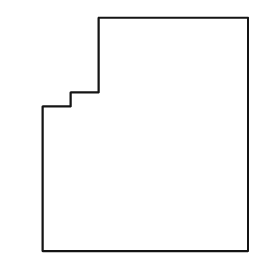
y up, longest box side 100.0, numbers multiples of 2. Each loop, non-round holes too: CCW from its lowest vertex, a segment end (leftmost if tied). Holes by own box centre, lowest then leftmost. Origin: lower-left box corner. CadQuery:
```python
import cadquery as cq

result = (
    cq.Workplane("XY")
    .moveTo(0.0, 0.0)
    .lineTo(88.0, 0.0)
    .lineTo(88.0, 100.0)
    .lineTo(24.0, 100.0)
    .lineTo(24.0, 68.0)
    .lineTo(12.0, 68.0)
    .lineTo(12.0, 62.0)
    .lineTo(0.0, 62.0)
    .close()
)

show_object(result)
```